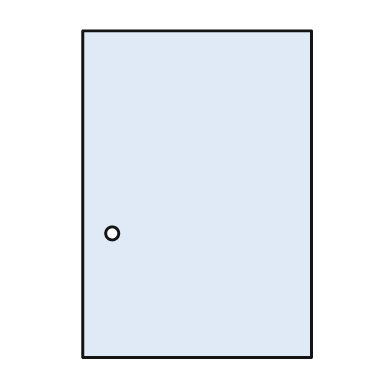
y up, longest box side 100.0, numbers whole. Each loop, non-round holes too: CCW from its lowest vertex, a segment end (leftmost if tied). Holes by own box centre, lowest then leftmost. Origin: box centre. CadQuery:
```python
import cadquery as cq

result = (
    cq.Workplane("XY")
    .moveTo(-35.0, -50.0)
    .lineTo(35.0, -50.0)
    .lineTo(35.0, 50.0)
    .lineTo(-35.0, 50.0)
    .close()
    .moveTo(-26.0, -12.0)
    .circle(2.0)
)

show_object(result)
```